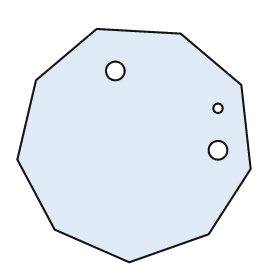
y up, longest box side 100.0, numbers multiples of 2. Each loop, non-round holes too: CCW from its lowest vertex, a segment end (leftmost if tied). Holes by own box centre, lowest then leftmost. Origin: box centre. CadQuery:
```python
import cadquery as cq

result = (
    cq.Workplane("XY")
    .moveTo(-2.0, -50.0)
    .lineTo(32.0, -38.0)
    .lineTo(50.0, -10.0)
    .lineTo(46.0, 26.0)
    .lineTo(20.0, 48.0)
    .lineTo(-16.0, 50.0)
    .lineTo(-42.0, 28.0)
    .lineTo(-50.0, -6.0)
    .lineTo(-34.0, -36.0)
    .close()
    .moveTo(36.0, -2.0)
    .circle(4.0)
    .moveTo(36.0, 16.0)
    .circle(2.0)
    .moveTo(-8.0, 32.0)
    .circle(4.0)
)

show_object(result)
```